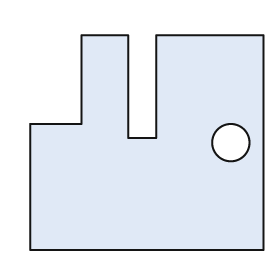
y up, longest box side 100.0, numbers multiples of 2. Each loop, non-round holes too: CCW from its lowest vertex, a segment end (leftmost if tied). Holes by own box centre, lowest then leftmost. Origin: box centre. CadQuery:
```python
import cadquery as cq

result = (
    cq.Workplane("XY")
    .moveTo(-50.0, -46.0)
    .lineTo(50.0, -46.0)
    .lineTo(50.0, 46.0)
    .lineTo(4.0, 46.0)
    .lineTo(4.0, 2.0)
    .lineTo(-8.0, 2.0)
    .lineTo(-8.0, 46.0)
    .lineTo(-28.0, 46.0)
    .lineTo(-28.0, 8.0)
    .lineTo(-50.0, 8.0)
    .close()
    .moveTo(36.0, 0.0)
    .circle(8.0)
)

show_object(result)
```